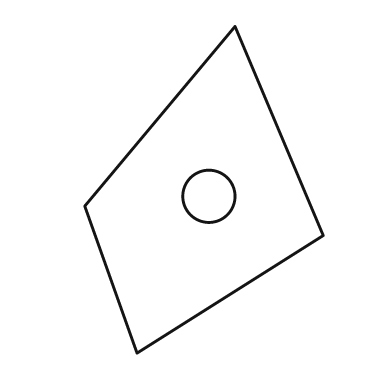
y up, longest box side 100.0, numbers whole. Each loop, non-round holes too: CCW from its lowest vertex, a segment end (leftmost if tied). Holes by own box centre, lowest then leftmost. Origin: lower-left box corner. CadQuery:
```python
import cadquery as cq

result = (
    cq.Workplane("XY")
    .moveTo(16.0, 0.0)
    .lineTo(73.0, 36.0)
    .lineTo(46.0, 100.0)
    .lineTo(0.0, 45.0)
    .close()
    .moveTo(38.0, 48.0)
    .circle(8.0)
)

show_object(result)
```